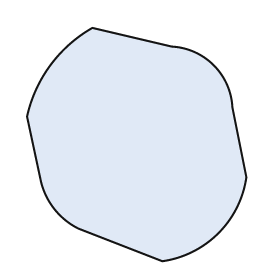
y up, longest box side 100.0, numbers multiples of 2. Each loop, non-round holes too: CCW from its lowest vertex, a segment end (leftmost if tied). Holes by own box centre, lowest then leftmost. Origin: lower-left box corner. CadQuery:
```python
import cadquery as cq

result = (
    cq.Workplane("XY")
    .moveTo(58.0, 0.0)
    .threePointArc((82.0, 12.0), (94.0, 36.0))
    .lineTo(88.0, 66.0)
    .threePointArc((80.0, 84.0), (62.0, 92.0))
    .lineTo(28.0, 100.0)
    .threePointArc((10.0, 84.0), (0.0, 62.0))
    .lineTo(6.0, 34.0)
    .threePointArc((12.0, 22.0), (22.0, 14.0))
    .close()
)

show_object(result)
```